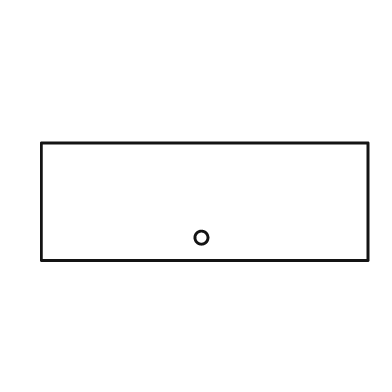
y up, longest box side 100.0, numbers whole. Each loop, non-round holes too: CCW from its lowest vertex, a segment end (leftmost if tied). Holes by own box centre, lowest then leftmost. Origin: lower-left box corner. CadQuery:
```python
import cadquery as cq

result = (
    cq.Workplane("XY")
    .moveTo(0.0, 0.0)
    .lineTo(100.0, 0.0)
    .lineTo(100.0, 36.0)
    .lineTo(0.0, 36.0)
    .close()
    .moveTo(49.0, 7.0)
    .circle(2.0)
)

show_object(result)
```